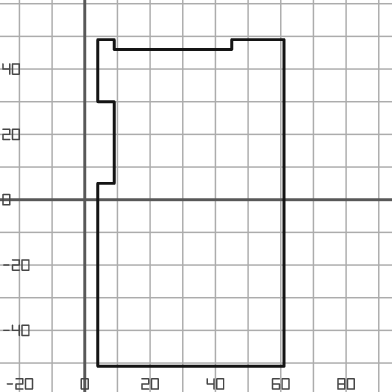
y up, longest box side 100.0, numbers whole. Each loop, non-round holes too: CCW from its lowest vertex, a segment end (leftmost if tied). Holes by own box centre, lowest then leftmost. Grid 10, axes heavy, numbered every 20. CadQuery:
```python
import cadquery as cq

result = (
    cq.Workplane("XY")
    .moveTo(4.0, -51.0)
    .lineTo(61.0, -51.0)
    .lineTo(61.0, 49.0)
    .lineTo(45.0, 49.0)
    .lineTo(45.0, 46.0)
    .lineTo(9.0, 46.0)
    .lineTo(9.0, 49.0)
    .lineTo(4.0, 49.0)
    .lineTo(4.0, 30.0)
    .lineTo(9.0, 30.0)
    .lineTo(9.0, 5.0)
    .lineTo(4.0, 5.0)
    .close()
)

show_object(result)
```